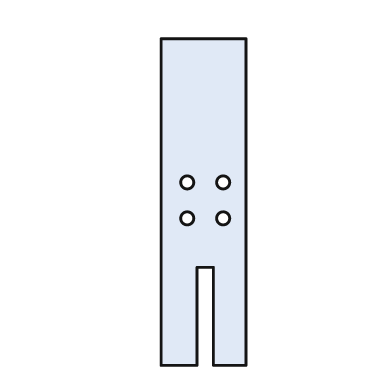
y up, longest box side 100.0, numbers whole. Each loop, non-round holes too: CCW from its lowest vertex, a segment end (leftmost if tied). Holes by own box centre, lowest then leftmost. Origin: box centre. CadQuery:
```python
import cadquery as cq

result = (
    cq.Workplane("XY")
    .moveTo(-13.0, -50.0)
    .lineTo(-2.0, -50.0)
    .lineTo(-2.0, -20.0)
    .lineTo(3.0, -20.0)
    .lineTo(3.0, -50.0)
    .lineTo(13.0, -50.0)
    .lineTo(13.0, 50.0)
    .lineTo(-13.0, 50.0)
    .close()
    .moveTo(-5.0, -5.0)
    .circle(2.0)
    .moveTo(6.0, -5.0)
    .circle(2.0)
    .moveTo(-5.0, 6.0)
    .circle(2.0)
    .moveTo(6.0, 6.0)
    .circle(2.0)
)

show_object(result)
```